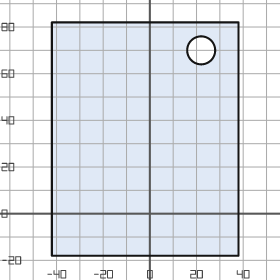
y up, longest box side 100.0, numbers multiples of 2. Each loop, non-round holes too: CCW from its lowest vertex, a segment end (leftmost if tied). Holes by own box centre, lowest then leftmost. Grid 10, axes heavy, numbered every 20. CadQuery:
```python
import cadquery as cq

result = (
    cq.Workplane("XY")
    .moveTo(-42.0, -18.0)
    .lineTo(38.0, -18.0)
    .lineTo(38.0, 82.0)
    .lineTo(-42.0, 82.0)
    .close()
    .moveTo(22.0, 70.0)
    .circle(6.0)
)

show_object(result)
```